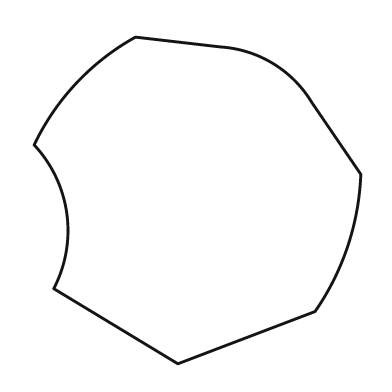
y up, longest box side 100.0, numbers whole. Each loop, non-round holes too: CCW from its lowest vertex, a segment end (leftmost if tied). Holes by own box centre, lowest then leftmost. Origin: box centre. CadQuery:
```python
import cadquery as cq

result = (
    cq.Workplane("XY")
    .moveTo(-6.0, -50.0)
    .lineTo(36.0, -34.0)
    .threePointArc((46.0, -14.0), (50.0, 8.0))
    .lineTo(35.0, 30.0)
    .threePointArc((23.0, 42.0), (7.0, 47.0))
    .lineTo(-19.0, 50.0)
    .threePointArc((-37.0, 36.0), (-50.0, 17.0))
    .threePointArc((-40.0, -4.0), (-44.0, -27.0))
    .close()
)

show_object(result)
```